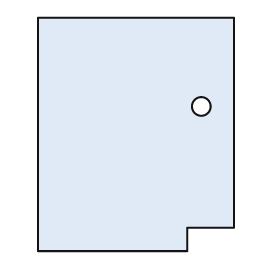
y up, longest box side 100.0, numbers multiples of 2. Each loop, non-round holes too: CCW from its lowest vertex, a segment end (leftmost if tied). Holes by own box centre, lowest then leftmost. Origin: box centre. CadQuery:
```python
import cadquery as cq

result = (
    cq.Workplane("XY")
    .moveTo(-42.0, -50.0)
    .lineTo(22.0, -50.0)
    .lineTo(22.0, -40.0)
    .lineTo(42.0, -40.0)
    .lineTo(42.0, 50.0)
    .lineTo(-42.0, 50.0)
    .close()
    .moveTo(28.0, 12.0)
    .circle(4.0)
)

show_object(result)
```